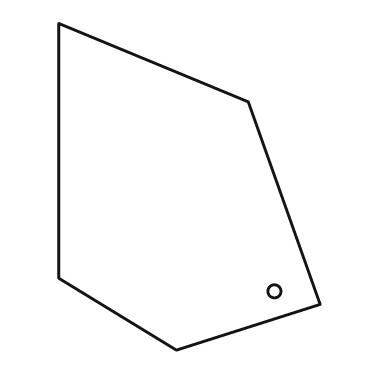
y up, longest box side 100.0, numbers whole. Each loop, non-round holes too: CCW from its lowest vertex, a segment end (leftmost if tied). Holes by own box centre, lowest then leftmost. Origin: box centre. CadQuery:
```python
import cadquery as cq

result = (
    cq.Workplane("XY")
    .moveTo(-4.0, -50.0)
    .lineTo(40.0, -36.0)
    .lineTo(18.0, 26.0)
    .lineTo(-40.0, 50.0)
    .lineTo(-40.0, -28.0)
    .close()
    .moveTo(26.0, -32.0)
    .circle(2.0)
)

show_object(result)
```